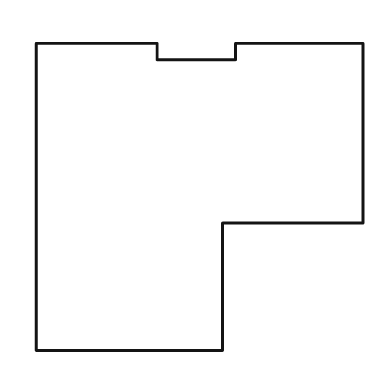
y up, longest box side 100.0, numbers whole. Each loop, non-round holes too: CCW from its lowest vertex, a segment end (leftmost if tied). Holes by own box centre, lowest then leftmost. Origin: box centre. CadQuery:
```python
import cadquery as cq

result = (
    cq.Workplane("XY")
    .moveTo(-50.0, -47.0)
    .lineTo(7.0, -47.0)
    .lineTo(7.0, -8.0)
    .lineTo(50.0, -8.0)
    .lineTo(50.0, 47.0)
    .lineTo(11.0, 47.0)
    .lineTo(11.0, 42.0)
    .lineTo(-13.0, 42.0)
    .lineTo(-13.0, 47.0)
    .lineTo(-50.0, 47.0)
    .close()
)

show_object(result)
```